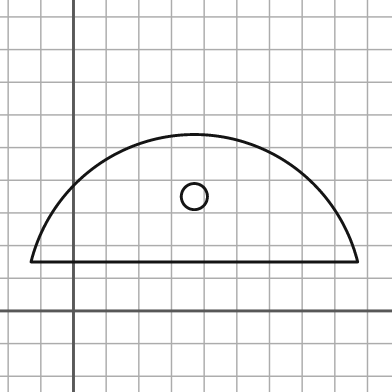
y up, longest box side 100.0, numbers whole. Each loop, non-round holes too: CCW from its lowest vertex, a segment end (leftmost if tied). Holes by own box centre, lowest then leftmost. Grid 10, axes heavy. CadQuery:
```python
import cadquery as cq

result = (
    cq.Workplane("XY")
    .moveTo(-13.0, 15.0)
    .lineTo(87.0, 15.0)
    .threePointArc((37.0, 54.0), (-13.0, 15.0))
    .close()
    .moveTo(37.0, 35.0)
    .circle(4.0)
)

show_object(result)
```